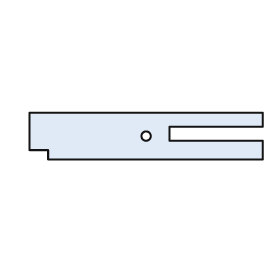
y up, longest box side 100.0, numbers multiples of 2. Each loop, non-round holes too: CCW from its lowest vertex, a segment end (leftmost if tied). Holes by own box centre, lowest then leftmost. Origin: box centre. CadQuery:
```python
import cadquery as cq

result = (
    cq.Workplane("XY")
    .moveTo(-42.0, -10.0)
    .lineTo(50.0, -10.0)
    .lineTo(50.0, -2.0)
    .lineTo(10.0, -2.0)
    .lineTo(10.0, 4.0)
    .lineTo(50.0, 4.0)
    .lineTo(50.0, 10.0)
    .lineTo(-50.0, 10.0)
    .lineTo(-50.0, -6.0)
    .lineTo(-42.0, -6.0)
    .close()
    .moveTo(0.0, 0.0)
    .circle(2.0)
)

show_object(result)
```